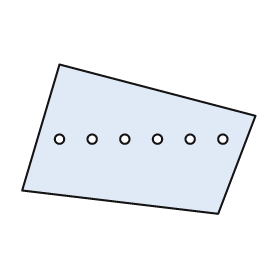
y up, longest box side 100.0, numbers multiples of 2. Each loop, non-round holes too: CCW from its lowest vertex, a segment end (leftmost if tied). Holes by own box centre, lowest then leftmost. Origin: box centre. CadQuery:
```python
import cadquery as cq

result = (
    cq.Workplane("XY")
    .moveTo(34.0, -32.0)
    .lineTo(50.0, 10.0)
    .lineTo(-34.0, 32.0)
    .lineTo(-50.0, -22.0)
    .close()
    .moveTo(-34.0, 0.0)
    .circle(2.0)
    .moveTo(-20.0, 0.0)
    .circle(2.0)
    .moveTo(-6.0, 0.0)
    .circle(2.0)
    .moveTo(8.0, 0.0)
    .circle(2.0)
    .moveTo(22.0, 0.0)
    .circle(2.0)
    .moveTo(36.0, 0.0)
    .circle(2.0)
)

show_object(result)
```